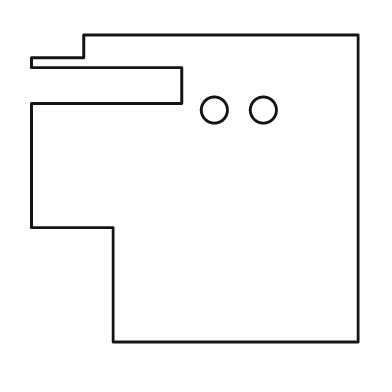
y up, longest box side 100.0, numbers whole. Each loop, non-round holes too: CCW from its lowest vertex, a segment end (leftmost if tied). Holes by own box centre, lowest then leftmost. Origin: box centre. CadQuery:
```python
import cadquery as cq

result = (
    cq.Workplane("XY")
    .moveTo(-25.0, -47.0)
    .lineTo(50.0, -47.0)
    .lineTo(50.0, 47.0)
    .lineTo(-34.0, 47.0)
    .lineTo(-34.0, 40.0)
    .lineTo(-50.0, 40.0)
    .lineTo(-50.0, 37.0)
    .lineTo(-4.0, 37.0)
    .lineTo(-4.0, 26.0)
    .lineTo(-50.0, 26.0)
    .lineTo(-50.0, -12.0)
    .lineTo(-25.0, -12.0)
    .close()
    .moveTo(6.0, 24.0)
    .circle(4.0)
    .moveTo(21.0, 24.0)
    .circle(4.0)
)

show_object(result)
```